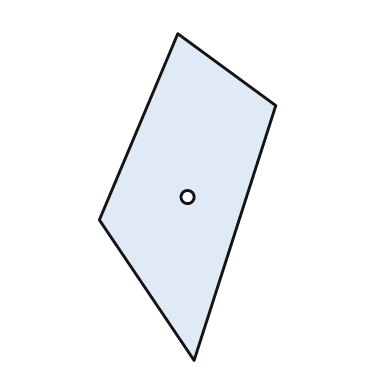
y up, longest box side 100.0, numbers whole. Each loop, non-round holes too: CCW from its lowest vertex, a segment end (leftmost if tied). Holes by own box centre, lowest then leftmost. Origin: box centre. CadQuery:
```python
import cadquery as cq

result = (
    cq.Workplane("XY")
    .moveTo(2.0, -50.0)
    .lineTo(27.0, 28.0)
    .lineTo(-3.0, 50.0)
    .lineTo(-27.0, -7.0)
    .close()
    .moveTo(0.0, 0.0)
    .circle(2.0)
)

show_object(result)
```